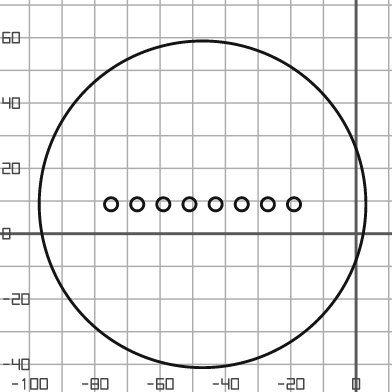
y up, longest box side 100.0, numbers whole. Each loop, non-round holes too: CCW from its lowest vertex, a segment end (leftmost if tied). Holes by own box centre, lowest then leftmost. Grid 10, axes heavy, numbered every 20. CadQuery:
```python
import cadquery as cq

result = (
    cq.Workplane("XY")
    .moveTo(-47.0, 9.0)
    .circle(50.0)
    .moveTo(-75.0, 9.0)
    .circle(2.0)
    .moveTo(-67.0, 9.0)
    .circle(2.0)
    .moveTo(-59.0, 9.0)
    .circle(2.0)
    .moveTo(-51.0, 9.0)
    .circle(2.0)
    .moveTo(-43.0, 9.0)
    .circle(2.0)
    .moveTo(-35.0, 9.0)
    .circle(2.0)
    .moveTo(-27.0, 9.0)
    .circle(2.0)
    .moveTo(-19.0, 9.0)
    .circle(2.0)
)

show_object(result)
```